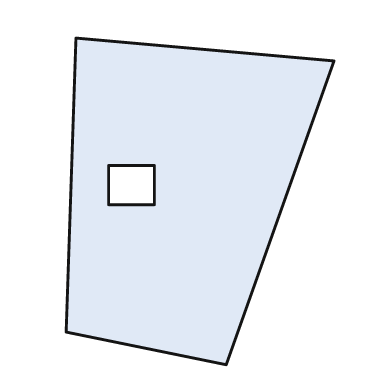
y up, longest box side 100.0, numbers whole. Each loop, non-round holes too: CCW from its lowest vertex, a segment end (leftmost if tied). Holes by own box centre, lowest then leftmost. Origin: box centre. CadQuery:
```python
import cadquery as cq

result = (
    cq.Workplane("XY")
    .moveTo(8.0, -50.0)
    .lineTo(41.0, 43.0)
    .lineTo(-38.0, 50.0)
    .lineTo(-41.0, -40.0)
    .close()
    .moveTo(-28.0, -1.0)
    .lineTo(-14.0, -1.0)
    .lineTo(-14.0, 11.0)
    .lineTo(-28.0, 11.0)
    .close()
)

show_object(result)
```